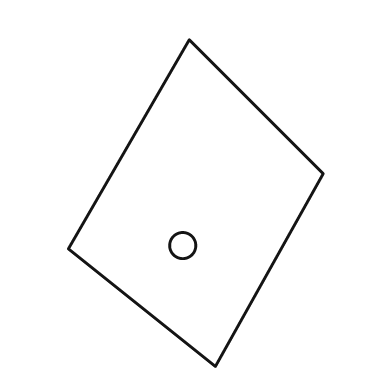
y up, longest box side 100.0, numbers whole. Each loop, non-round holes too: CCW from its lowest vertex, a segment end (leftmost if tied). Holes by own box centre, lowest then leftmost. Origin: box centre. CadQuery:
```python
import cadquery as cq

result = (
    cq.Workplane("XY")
    .moveTo(6.0, -50.0)
    .lineTo(39.0, 9.0)
    .lineTo(-2.0, 50.0)
    .lineTo(-39.0, -14.0)
    .close()
    .moveTo(-4.0, -13.0)
    .circle(4.0)
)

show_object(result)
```